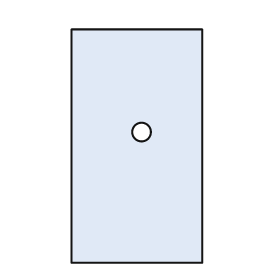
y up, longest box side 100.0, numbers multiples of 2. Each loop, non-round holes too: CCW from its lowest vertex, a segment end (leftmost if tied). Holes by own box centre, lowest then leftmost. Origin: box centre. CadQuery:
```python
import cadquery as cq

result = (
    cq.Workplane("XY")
    .moveTo(-28.0, -50.0)
    .lineTo(28.0, -50.0)
    .lineTo(28.0, 50.0)
    .lineTo(-28.0, 50.0)
    .close()
    .moveTo(2.0, 6.0)
    .circle(4.0)
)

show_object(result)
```